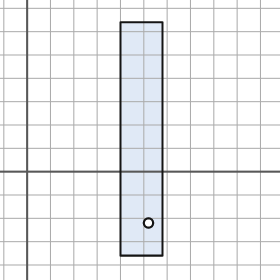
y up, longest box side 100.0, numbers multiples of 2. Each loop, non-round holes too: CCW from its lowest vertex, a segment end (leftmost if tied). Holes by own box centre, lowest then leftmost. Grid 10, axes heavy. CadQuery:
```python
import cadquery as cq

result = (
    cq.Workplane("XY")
    .moveTo(40.0, -36.0)
    .lineTo(58.0, -36.0)
    .lineTo(58.0, 64.0)
    .lineTo(40.0, 64.0)
    .close()
    .moveTo(52.0, -22.0)
    .circle(2.0)
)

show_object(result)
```